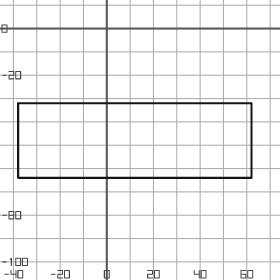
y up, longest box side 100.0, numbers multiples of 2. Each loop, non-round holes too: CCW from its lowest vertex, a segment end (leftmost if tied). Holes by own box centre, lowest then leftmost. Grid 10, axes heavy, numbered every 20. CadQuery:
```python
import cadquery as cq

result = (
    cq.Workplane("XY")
    .moveTo(-38.0, -64.0)
    .lineTo(62.0, -64.0)
    .lineTo(62.0, -32.0)
    .lineTo(-38.0, -32.0)
    .close()
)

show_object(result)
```